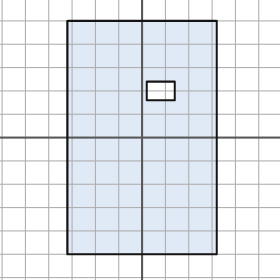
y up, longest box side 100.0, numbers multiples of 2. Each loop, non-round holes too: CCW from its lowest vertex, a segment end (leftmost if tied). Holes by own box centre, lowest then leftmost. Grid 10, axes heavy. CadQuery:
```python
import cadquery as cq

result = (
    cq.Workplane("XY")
    .moveTo(-32.0, -50.0)
    .lineTo(32.0, -50.0)
    .lineTo(32.0, 50.0)
    .lineTo(-32.0, 50.0)
    .close()
    .moveTo(2.0, 16.0)
    .lineTo(14.0, 16.0)
    .lineTo(14.0, 24.0)
    .lineTo(2.0, 24.0)
    .close()
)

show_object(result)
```